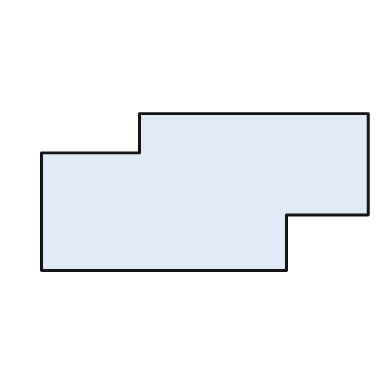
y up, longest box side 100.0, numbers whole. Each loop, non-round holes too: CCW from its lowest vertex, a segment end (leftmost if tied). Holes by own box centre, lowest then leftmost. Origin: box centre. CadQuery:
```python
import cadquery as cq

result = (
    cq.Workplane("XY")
    .moveTo(-50.0, -24.0)
    .lineTo(25.0, -24.0)
    .lineTo(25.0, -7.0)
    .lineTo(50.0, -7.0)
    .lineTo(50.0, 24.0)
    .lineTo(-20.0, 24.0)
    .lineTo(-20.0, 12.0)
    .lineTo(-50.0, 12.0)
    .close()
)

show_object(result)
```